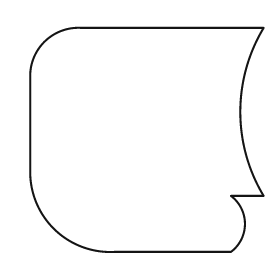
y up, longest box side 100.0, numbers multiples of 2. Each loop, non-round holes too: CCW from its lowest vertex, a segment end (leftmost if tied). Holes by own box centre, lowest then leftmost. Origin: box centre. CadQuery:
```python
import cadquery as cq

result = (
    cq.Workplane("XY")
    .moveTo(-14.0, -48.0)
    .lineTo(36.0, -48.0)
    .threePointArc((42.0, -36.0), (36.0, -24.0))
    .lineTo(50.0, -24.0)
    .threePointArc((40.0, 12.0), (50.0, 48.0))
    .lineTo(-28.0, 48.0)
    .threePointArc((-44.0, 42.0), (-50.0, 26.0))
    .lineTo(-50.0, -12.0)
    .threePointArc((-40.0, -38.0), (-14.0, -48.0))
    .close()
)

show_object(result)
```